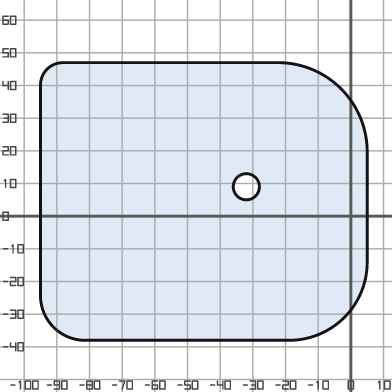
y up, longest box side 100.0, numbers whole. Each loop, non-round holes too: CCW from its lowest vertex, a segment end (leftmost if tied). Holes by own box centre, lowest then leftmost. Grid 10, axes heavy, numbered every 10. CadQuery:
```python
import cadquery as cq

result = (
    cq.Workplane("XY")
    .moveTo(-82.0, -38.0)
    .lineTo(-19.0, -38.0)
    .threePointArc((-2.0, -31.0), (5.0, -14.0))
    .lineTo(5.0, 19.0)
    .threePointArc((-3.0, 39.0), (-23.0, 47.0))
    .lineTo(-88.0, 47.0)
    .threePointArc((-93.0, 45.0), (-95.0, 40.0))
    .lineTo(-95.0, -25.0)
    .threePointArc((-91.0, -34.0), (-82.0, -38.0))
    .close()
    .moveTo(-32.0, 9.0)
    .circle(4.0)
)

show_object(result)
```